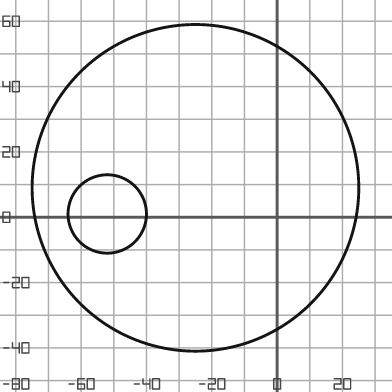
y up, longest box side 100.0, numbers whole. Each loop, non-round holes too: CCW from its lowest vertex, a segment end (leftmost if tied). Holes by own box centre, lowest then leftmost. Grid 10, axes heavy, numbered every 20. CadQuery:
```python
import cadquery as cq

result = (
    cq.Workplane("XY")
    .moveTo(-25.0, 9.0)
    .circle(50.0)
    .moveTo(-52.0, 1.0)
    .circle(12.0)
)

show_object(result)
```